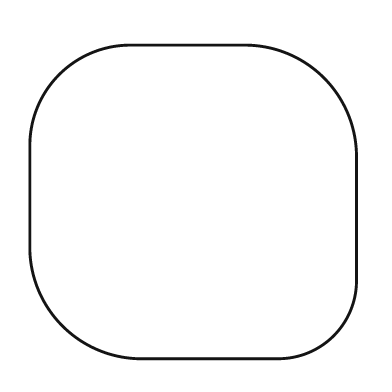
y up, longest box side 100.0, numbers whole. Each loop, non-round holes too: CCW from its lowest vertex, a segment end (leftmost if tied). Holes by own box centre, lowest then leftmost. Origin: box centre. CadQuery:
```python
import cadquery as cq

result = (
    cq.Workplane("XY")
    .moveTo(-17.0, -48.0)
    .lineTo(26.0, -48.0)
    .threePointArc((43.0, -41.0), (50.0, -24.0))
    .lineTo(50.0, 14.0)
    .threePointArc((40.0, 38.0), (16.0, 48.0))
    .lineTo(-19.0, 48.0)
    .threePointArc((-41.0, 39.0), (-50.0, 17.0))
    .lineTo(-50.0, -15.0)
    .threePointArc((-40.0, -38.0), (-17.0, -48.0))
    .close()
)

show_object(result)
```